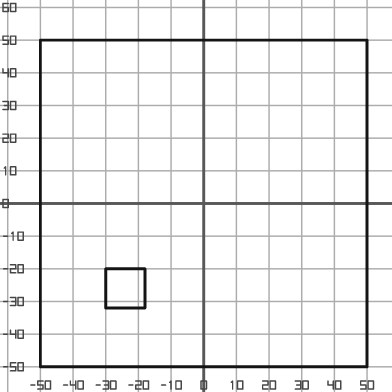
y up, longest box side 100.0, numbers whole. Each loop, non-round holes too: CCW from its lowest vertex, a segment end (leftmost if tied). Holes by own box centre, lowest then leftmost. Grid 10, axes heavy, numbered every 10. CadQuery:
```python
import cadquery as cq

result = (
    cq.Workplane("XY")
    .moveTo(-50.0, -50.0)
    .lineTo(50.0, -50.0)
    .lineTo(50.0, 50.0)
    .lineTo(-50.0, 50.0)
    .close()
    .moveTo(-30.0, -32.0)
    .lineTo(-18.0, -32.0)
    .lineTo(-18.0, -20.0)
    .lineTo(-30.0, -20.0)
    .close()
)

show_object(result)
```